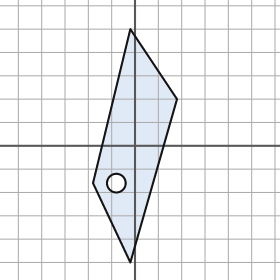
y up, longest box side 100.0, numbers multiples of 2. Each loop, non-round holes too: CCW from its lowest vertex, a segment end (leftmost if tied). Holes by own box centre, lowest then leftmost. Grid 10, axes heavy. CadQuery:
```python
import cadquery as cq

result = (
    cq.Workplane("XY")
    .moveTo(-2.0, -50.0)
    .lineTo(18.0, 20.0)
    .lineTo(-2.0, 50.0)
    .lineTo(-18.0, -16.0)
    .close()
    .moveTo(-8.0, -16.0)
    .circle(4.0)
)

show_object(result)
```